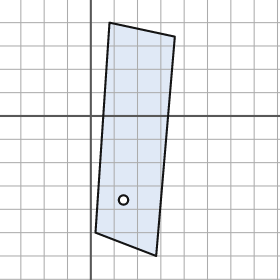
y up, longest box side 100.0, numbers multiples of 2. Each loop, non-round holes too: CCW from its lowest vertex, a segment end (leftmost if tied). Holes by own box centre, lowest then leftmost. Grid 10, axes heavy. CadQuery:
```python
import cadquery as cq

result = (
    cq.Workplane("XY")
    .moveTo(28.0, -60.0)
    .lineTo(36.0, 34.0)
    .lineTo(8.0, 40.0)
    .lineTo(2.0, -50.0)
    .close()
    .moveTo(14.0, -36.0)
    .circle(2.0)
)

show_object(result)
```